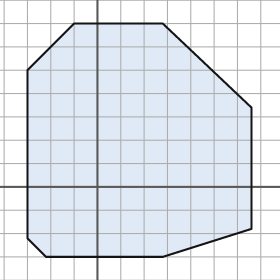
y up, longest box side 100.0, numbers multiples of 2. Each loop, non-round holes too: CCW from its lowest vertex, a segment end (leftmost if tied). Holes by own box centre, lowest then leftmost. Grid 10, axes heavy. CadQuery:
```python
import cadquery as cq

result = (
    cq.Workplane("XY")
    .moveTo(-22.0, -30.0)
    .lineTo(28.0, -30.0)
    .lineTo(66.0, -18.0)
    .lineTo(66.0, 34.0)
    .lineTo(28.0, 70.0)
    .lineTo(-10.0, 70.0)
    .lineTo(-30.0, 50.0)
    .lineTo(-30.0, -22.0)
    .close()
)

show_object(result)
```